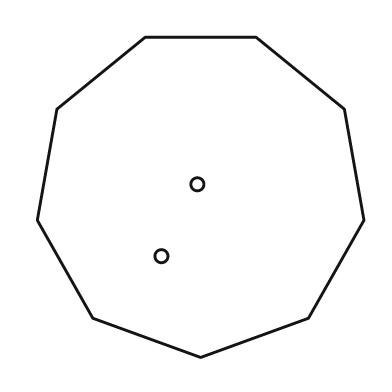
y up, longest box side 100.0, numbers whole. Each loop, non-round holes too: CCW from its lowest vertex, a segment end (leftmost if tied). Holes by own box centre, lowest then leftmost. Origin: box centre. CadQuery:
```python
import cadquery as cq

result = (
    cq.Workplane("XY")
    .moveTo(0.0, -49.0)
    .lineTo(33.0, -37.0)
    .lineTo(50.0, -7.0)
    .lineTo(44.0, 27.0)
    .lineTo(17.0, 49.0)
    .lineTo(-17.0, 49.0)
    .lineTo(-44.0, 27.0)
    .lineTo(-50.0, -7.0)
    .lineTo(-33.0, -37.0)
    .close()
    .moveTo(-12.0, -18.0)
    .circle(2.0)
    .moveTo(-1.0, 4.0)
    .circle(2.0)
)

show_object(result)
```